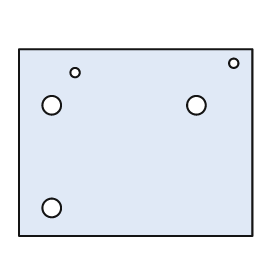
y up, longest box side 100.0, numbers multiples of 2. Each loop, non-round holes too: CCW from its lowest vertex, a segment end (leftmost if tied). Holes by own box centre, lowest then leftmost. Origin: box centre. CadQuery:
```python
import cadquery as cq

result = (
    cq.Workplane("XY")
    .moveTo(-50.0, -40.0)
    .lineTo(50.0, -40.0)
    .lineTo(50.0, 40.0)
    .lineTo(-50.0, 40.0)
    .close()
    .moveTo(-36.0, -28.0)
    .circle(4.0)
    .moveTo(-36.0, 16.0)
    .circle(4.0)
    .moveTo(26.0, 16.0)
    .circle(4.0)
    .moveTo(-26.0, 30.0)
    .circle(2.0)
    .moveTo(42.0, 34.0)
    .circle(2.0)
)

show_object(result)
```